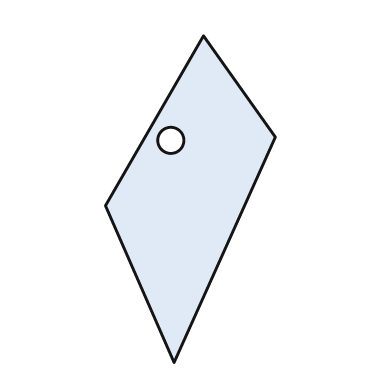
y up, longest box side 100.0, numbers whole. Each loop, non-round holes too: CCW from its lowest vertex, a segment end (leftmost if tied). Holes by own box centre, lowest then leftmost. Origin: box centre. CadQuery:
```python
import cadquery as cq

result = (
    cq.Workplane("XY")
    .moveTo(-5.0, -50.0)
    .lineTo(26.0, 19.0)
    .lineTo(4.0, 50.0)
    .lineTo(-26.0, -2.0)
    .close()
    .moveTo(-6.0, 18.0)
    .circle(4.0)
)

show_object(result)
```